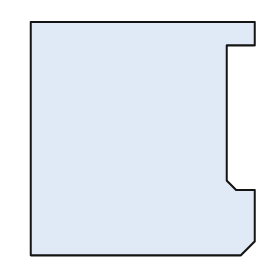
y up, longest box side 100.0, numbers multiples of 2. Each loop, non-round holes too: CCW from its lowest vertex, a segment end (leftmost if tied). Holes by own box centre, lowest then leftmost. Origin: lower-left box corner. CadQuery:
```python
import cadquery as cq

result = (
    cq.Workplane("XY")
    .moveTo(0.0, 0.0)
    .lineTo(90.0, 0.0)
    .lineTo(96.0, 6.0)
    .lineTo(96.0, 28.0)
    .lineTo(88.0, 28.0)
    .lineTo(84.0, 32.0)
    .lineTo(84.0, 90.0)
    .lineTo(96.0, 90.0)
    .lineTo(96.0, 100.0)
    .lineTo(0.0, 100.0)
    .close()
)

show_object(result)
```